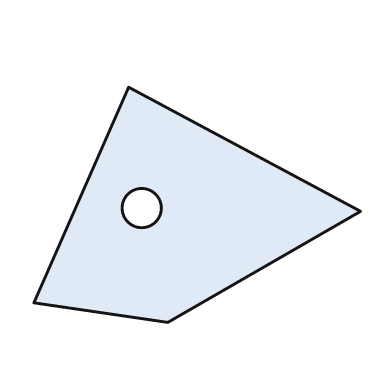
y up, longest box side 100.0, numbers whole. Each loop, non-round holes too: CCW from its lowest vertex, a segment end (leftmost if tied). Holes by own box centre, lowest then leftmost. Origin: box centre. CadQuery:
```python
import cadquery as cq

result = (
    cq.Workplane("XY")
    .moveTo(-9.0, -36.0)
    .lineTo(50.0, -2.0)
    .lineTo(-21.0, 36.0)
    .lineTo(-50.0, -30.0)
    .close()
    .moveTo(-17.0, -1.0)
    .circle(6.0)
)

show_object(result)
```